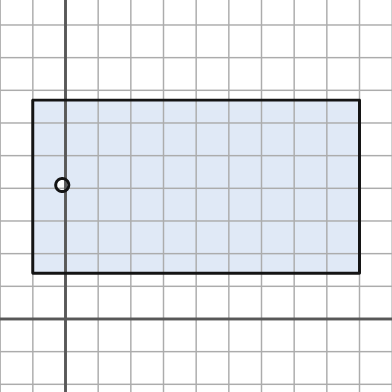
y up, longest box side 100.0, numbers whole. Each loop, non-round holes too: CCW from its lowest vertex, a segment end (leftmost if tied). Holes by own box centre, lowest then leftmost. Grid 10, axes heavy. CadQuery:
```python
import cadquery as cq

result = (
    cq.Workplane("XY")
    .moveTo(-10.0, 14.0)
    .lineTo(90.0, 14.0)
    .lineTo(90.0, 67.0)
    .lineTo(-10.0, 67.0)
    .close()
    .moveTo(-1.0, 41.0)
    .circle(2.0)
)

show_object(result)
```